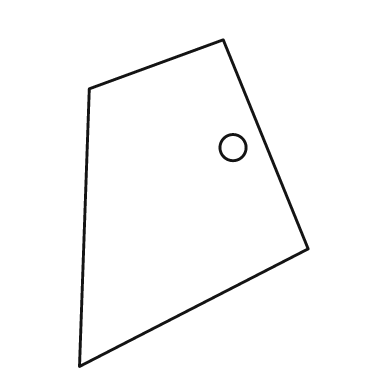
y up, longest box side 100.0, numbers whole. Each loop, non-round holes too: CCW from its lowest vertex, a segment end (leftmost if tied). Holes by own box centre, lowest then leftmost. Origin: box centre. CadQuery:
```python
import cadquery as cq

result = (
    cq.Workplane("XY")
    .moveTo(-35.0, -50.0)
    .lineTo(35.0, -14.0)
    .lineTo(9.0, 50.0)
    .lineTo(-32.0, 35.0)
    .close()
    .moveTo(12.0, 17.0)
    .circle(4.0)
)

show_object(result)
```